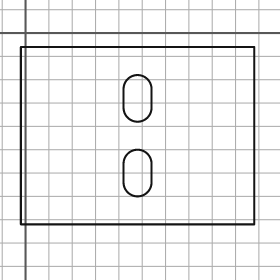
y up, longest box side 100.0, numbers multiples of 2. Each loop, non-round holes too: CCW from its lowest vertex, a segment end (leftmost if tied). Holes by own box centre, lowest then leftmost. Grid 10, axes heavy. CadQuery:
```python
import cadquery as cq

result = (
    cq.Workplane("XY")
    .moveTo(-2.0, -82.0)
    .lineTo(98.0, -82.0)
    .lineTo(98.0, -6.0)
    .lineTo(-2.0, -6.0)
    .close()
    .moveTo(42.0, -64.0)
    .threePointArc((48.0, -70.0), (54.0, -64.0))
    .lineTo(54.0, -56.0)
    .threePointArc((48.0, -50.0), (42.0, -56.0))
    .close()
    .moveTo(42.0, -32.0)
    .threePointArc((48.0, -38.0), (54.0, -32.0))
    .lineTo(54.0, -24.0)
    .threePointArc((48.0, -18.0), (42.0, -24.0))
    .close()
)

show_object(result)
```